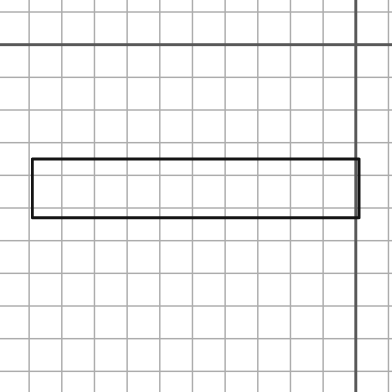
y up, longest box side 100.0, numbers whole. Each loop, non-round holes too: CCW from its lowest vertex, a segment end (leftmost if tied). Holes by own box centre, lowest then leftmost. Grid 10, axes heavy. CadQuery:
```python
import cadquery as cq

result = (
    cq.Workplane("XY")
    .moveTo(-99.0, -53.0)
    .lineTo(1.0, -53.0)
    .lineTo(1.0, -35.0)
    .lineTo(-99.0, -35.0)
    .close()
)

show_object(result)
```